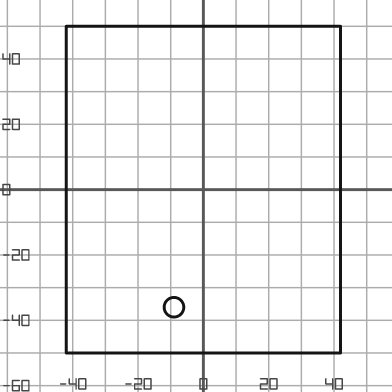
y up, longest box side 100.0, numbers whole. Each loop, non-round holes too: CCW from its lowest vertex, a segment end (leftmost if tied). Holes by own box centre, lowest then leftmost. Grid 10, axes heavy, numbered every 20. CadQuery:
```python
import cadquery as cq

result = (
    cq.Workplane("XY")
    .moveTo(-42.0, -50.0)
    .lineTo(42.0, -50.0)
    .lineTo(42.0, 50.0)
    .lineTo(-42.0, 50.0)
    .close()
    .moveTo(-9.0, -36.0)
    .circle(3.0)
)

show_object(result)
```